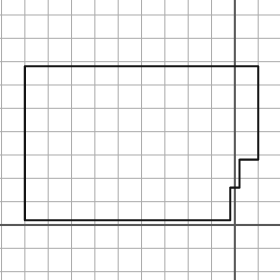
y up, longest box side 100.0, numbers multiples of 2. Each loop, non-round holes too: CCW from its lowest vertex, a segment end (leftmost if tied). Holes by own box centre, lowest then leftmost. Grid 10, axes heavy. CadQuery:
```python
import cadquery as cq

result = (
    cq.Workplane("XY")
    .moveTo(-90.0, 2.0)
    .lineTo(-2.0, 2.0)
    .lineTo(-2.0, 16.0)
    .lineTo(2.0, 16.0)
    .lineTo(2.0, 28.0)
    .lineTo(10.0, 28.0)
    .lineTo(10.0, 68.0)
    .lineTo(-90.0, 68.0)
    .close()
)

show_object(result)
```